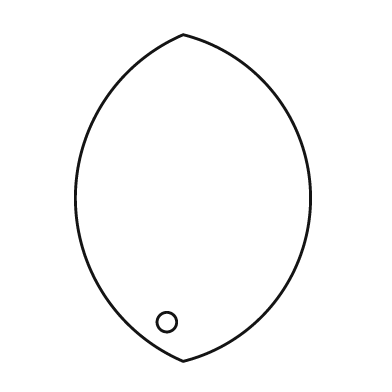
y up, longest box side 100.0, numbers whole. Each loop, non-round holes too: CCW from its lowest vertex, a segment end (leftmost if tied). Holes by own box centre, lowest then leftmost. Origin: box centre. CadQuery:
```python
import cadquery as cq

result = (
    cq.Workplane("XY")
    .moveTo(-3.0, -50.0)
    .threePointArc((36.0, 0.0), (-3.0, 50.0))
    .threePointArc((-36.0, 0.0), (-3.0, -50.0))
    .close()
    .moveTo(-8.0, -38.0)
    .circle(3.0)
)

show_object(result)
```